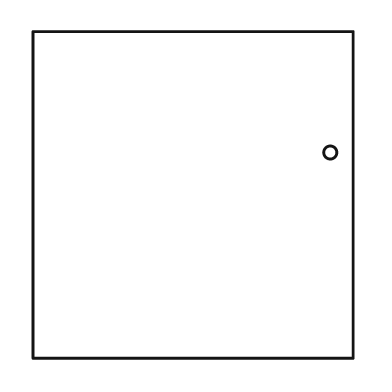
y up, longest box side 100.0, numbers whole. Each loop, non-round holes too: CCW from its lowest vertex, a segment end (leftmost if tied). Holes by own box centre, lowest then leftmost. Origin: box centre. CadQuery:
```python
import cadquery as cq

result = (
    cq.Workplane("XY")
    .moveTo(-49.0, -50.0)
    .lineTo(49.0, -50.0)
    .lineTo(49.0, 50.0)
    .lineTo(-49.0, 50.0)
    .close()
    .moveTo(42.0, 13.0)
    .circle(2.0)
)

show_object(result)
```